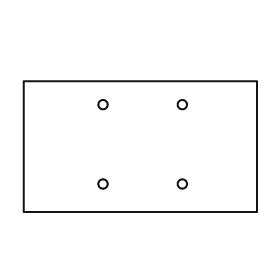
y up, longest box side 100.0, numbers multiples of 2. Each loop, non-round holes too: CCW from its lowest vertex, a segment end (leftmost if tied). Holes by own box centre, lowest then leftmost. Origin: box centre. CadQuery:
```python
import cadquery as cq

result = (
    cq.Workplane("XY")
    .moveTo(-50.0, -28.0)
    .lineTo(50.0, -28.0)
    .lineTo(50.0, 28.0)
    .lineTo(-50.0, 28.0)
    .close()
    .moveTo(-16.0, -16.0)
    .circle(2.0)
    .moveTo(18.0, -16.0)
    .circle(2.0)
    .moveTo(-16.0, 18.0)
    .circle(2.0)
    .moveTo(18.0, 18.0)
    .circle(2.0)
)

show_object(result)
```